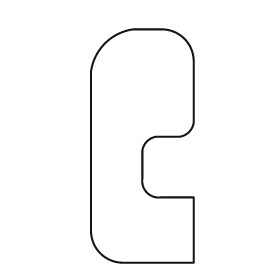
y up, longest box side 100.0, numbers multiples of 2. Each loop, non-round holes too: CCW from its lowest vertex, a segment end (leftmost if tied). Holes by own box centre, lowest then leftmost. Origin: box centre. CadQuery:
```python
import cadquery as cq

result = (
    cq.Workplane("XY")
    .moveTo(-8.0, -50.0)
    .lineTo(22.0, -50.0)
    .lineTo(22.0, -22.0)
    .lineTo(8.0, -22.0)
    .threePointArc((2.0, -20.0), (0.0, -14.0))
    .lineTo(0.0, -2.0)
    .threePointArc((2.0, 2.0), (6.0, 4.0))
    .lineTo(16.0, 4.0)
    .threePointArc((20.0, 6.0), (22.0, 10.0))
    .lineTo(22.0, 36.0)
    .threePointArc((18.0, 46.0), (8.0, 50.0))
    .lineTo(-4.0, 50.0)
    .threePointArc((-16.0, 44.0), (-22.0, 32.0))
    .lineTo(-22.0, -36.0)
    .threePointArc((-18.0, -46.0), (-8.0, -50.0))
    .close()
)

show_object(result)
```